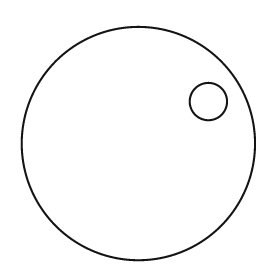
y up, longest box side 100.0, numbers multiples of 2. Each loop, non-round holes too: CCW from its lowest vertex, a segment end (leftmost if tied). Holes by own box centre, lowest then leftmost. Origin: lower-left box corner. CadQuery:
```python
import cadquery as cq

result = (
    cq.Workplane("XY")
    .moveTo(50.0, 50.0)
    .circle(50.0)
    .moveTo(80.0, 68.0)
    .circle(8.0)
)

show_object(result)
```